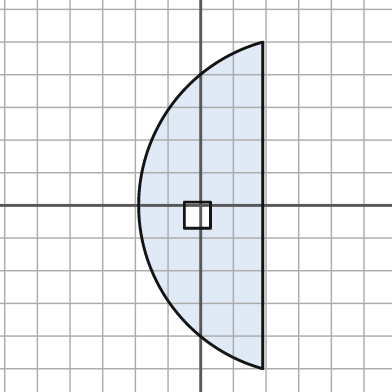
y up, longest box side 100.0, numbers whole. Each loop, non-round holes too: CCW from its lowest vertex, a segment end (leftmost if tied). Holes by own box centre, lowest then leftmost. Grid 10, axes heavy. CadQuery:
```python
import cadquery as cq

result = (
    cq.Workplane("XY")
    .moveTo(19.0, -50.0)
    .lineTo(19.0, 50.0)
    .threePointArc((-19.0, 0.0), (19.0, -50.0))
    .close()
    .moveTo(-5.0, -7.0)
    .lineTo(3.0, -7.0)
    .lineTo(3.0, 1.0)
    .lineTo(-5.0, 1.0)
    .close()
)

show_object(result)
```